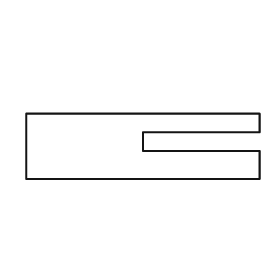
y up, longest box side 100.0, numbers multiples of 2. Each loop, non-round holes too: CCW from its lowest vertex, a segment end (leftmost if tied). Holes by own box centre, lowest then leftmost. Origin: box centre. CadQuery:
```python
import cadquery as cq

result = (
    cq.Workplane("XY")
    .moveTo(-50.0, -14.0)
    .lineTo(50.0, -14.0)
    .lineTo(50.0, -2.0)
    .lineTo(0.0, -2.0)
    .lineTo(0.0, 6.0)
    .lineTo(50.0, 6.0)
    .lineTo(50.0, 14.0)
    .lineTo(-50.0, 14.0)
    .close()
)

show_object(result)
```